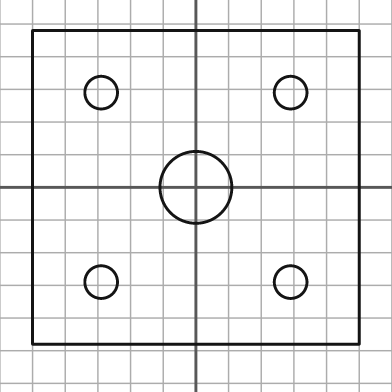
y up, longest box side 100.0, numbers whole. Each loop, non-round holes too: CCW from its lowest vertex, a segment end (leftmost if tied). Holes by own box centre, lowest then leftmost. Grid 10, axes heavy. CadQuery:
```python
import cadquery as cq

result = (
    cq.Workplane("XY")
    .moveTo(-50.0, -48.0)
    .lineTo(50.0, -48.0)
    .lineTo(50.0, 48.0)
    .lineTo(-50.0, 48.0)
    .close()
    .moveTo(-29.0, -29.0)
    .circle(5.0)
    .moveTo(29.0, -29.0)
    .circle(5.0)
    .moveTo(0.0, 0.0)
    .circle(11.0)
    .moveTo(-29.0, 29.0)
    .circle(5.0)
    .moveTo(29.0, 29.0)
    .circle(5.0)
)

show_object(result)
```